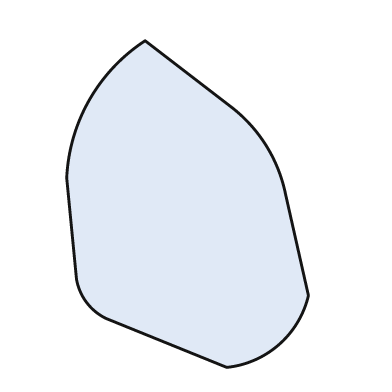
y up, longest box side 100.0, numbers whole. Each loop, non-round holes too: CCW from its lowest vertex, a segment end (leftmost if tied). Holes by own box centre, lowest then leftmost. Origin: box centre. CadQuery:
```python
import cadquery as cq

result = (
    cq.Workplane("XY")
    .moveTo(12.0, -50.0)
    .threePointArc((28.0, -43.0), (37.0, -28.0))
    .lineTo(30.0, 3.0)
    .threePointArc((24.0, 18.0), (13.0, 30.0))
    .lineTo(-13.0, 50.0)
    .threePointArc((-30.0, 32.0), (-37.0, 8.0))
    .lineTo(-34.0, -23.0)
    .threePointArc((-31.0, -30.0), (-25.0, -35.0))
    .close()
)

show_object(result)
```